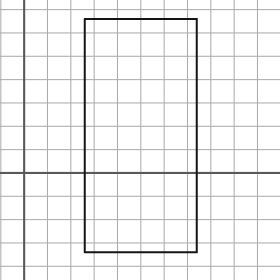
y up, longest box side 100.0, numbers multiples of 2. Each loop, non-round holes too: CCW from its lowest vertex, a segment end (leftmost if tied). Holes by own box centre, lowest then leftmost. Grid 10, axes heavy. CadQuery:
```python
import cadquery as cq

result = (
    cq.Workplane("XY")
    .moveTo(26.0, -34.0)
    .lineTo(74.0, -34.0)
    .lineTo(74.0, 66.0)
    .lineTo(26.0, 66.0)
    .close()
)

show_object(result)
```